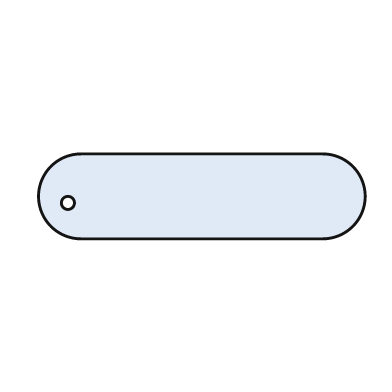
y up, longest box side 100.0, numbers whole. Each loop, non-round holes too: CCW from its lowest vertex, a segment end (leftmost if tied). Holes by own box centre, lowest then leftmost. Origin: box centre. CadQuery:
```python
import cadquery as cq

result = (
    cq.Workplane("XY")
    .moveTo(-37.0, -13.0)
    .lineTo(37.0, -13.0)
    .threePointArc((50.0, 0.0), (37.0, 13.0))
    .lineTo(-37.0, 13.0)
    .threePointArc((-50.0, 0.0), (-37.0, -13.0))
    .close()
    .moveTo(-41.0, -2.0)
    .circle(2.0)
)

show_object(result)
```